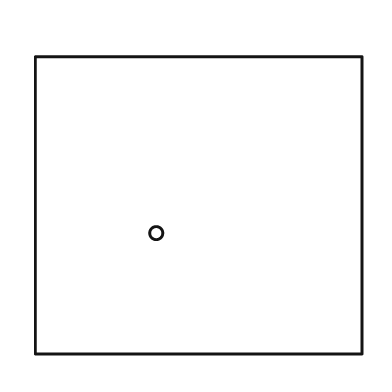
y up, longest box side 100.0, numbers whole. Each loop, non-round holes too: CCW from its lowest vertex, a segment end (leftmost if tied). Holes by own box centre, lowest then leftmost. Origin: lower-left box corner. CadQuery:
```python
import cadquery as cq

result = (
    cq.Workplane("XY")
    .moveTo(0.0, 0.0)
    .lineTo(100.0, 0.0)
    .lineTo(100.0, 91.0)
    .lineTo(0.0, 91.0)
    .close()
    .moveTo(37.0, 37.0)
    .circle(2.0)
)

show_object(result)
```